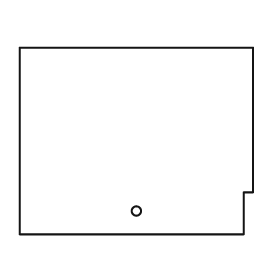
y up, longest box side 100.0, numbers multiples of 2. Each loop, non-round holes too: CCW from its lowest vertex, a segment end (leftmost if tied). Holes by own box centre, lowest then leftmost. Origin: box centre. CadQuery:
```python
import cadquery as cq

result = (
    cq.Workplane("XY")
    .moveTo(-50.0, -40.0)
    .lineTo(46.0, -40.0)
    .lineTo(46.0, -22.0)
    .lineTo(50.0, -22.0)
    .lineTo(50.0, 40.0)
    .lineTo(-50.0, 40.0)
    .close()
    .moveTo(0.0, -30.0)
    .circle(2.0)
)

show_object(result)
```